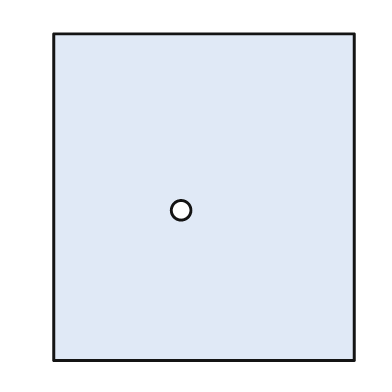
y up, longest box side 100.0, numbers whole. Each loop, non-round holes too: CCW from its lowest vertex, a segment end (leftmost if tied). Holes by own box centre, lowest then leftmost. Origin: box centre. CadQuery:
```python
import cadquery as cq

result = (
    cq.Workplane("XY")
    .moveTo(-46.0, -50.0)
    .lineTo(46.0, -50.0)
    .lineTo(46.0, 50.0)
    .lineTo(-46.0, 50.0)
    .close()
    .moveTo(-7.0, -4.0)
    .circle(3.0)
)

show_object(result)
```